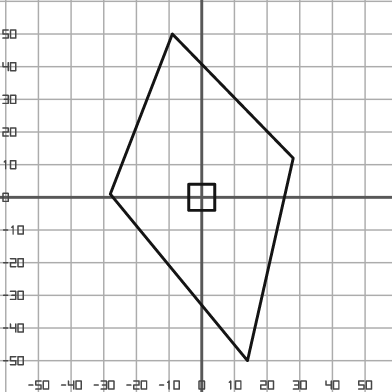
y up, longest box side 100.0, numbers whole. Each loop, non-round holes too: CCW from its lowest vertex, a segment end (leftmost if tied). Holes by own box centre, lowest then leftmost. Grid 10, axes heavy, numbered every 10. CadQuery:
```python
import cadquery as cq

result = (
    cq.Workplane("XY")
    .moveTo(14.0, -50.0)
    .lineTo(28.0, 12.0)
    .lineTo(-9.0, 50.0)
    .lineTo(-28.0, 1.0)
    .close()
    .moveTo(-4.0, -4.0)
    .lineTo(4.0, -4.0)
    .lineTo(4.0, 4.0)
    .lineTo(-4.0, 4.0)
    .close()
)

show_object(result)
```